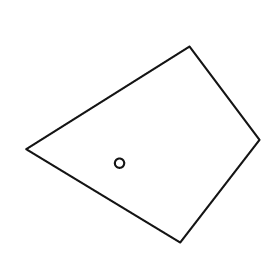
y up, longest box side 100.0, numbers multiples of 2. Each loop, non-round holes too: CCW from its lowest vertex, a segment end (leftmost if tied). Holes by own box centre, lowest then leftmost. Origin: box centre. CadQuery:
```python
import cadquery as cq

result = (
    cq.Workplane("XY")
    .moveTo(16.0, -42.0)
    .lineTo(50.0, 2.0)
    .lineTo(20.0, 42.0)
    .lineTo(-50.0, -2.0)
    .close()
    .moveTo(-10.0, -8.0)
    .circle(2.0)
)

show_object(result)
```